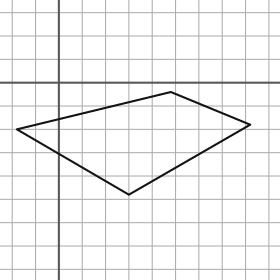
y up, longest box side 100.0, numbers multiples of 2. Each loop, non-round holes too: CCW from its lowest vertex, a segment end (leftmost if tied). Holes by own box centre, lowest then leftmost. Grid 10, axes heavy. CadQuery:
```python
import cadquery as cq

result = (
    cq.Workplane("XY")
    .moveTo(30.0, -48.0)
    .lineTo(82.0, -18.0)
    .lineTo(48.0, -4.0)
    .lineTo(-18.0, -20.0)
    .close()
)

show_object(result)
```